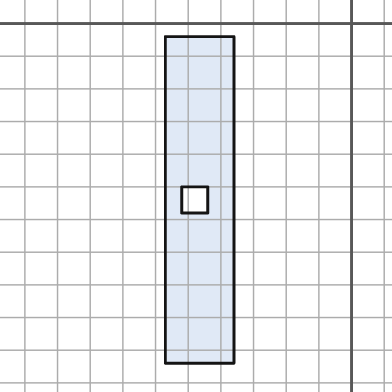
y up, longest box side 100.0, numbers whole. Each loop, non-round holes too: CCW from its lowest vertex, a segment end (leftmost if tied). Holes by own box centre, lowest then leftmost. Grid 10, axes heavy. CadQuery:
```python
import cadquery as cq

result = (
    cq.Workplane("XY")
    .moveTo(-57.0, -104.0)
    .lineTo(-36.0, -104.0)
    .lineTo(-36.0, -4.0)
    .lineTo(-57.0, -4.0)
    .close()
    .moveTo(-52.0, -58.0)
    .lineTo(-44.0, -58.0)
    .lineTo(-44.0, -50.0)
    .lineTo(-52.0, -50.0)
    .close()
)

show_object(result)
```